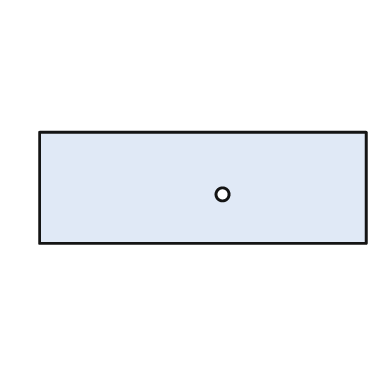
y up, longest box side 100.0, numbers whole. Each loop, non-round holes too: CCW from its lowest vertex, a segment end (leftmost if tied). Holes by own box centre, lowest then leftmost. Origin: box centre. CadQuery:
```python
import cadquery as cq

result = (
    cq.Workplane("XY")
    .moveTo(-50.0, -17.0)
    .lineTo(50.0, -17.0)
    .lineTo(50.0, 17.0)
    .lineTo(-50.0, 17.0)
    .close()
    .moveTo(6.0, -2.0)
    .circle(2.0)
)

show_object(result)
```